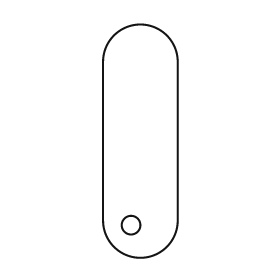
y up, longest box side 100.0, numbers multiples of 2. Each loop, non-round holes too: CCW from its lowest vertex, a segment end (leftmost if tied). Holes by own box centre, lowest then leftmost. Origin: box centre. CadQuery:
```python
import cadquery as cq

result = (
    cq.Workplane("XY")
    .moveTo(-16.0, -34.0)
    .threePointArc((0.0, -50.0), (16.0, -34.0))
    .lineTo(16.0, 34.0)
    .threePointArc((0.0, 50.0), (-16.0, 34.0))
    .close()
    .moveTo(-4.0, -36.0)
    .circle(4.0)
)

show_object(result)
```